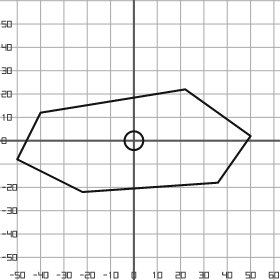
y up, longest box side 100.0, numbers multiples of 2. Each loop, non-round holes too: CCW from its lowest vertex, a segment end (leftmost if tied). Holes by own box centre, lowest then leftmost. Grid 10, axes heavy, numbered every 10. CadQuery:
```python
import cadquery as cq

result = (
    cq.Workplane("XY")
    .moveTo(-22.0, -22.0)
    .lineTo(36.0, -18.0)
    .lineTo(50.0, 2.0)
    .lineTo(22.0, 22.0)
    .lineTo(-40.0, 12.0)
    .lineTo(-50.0, -8.0)
    .close()
    .moveTo(0.0, 0.0)
    .circle(4.0)
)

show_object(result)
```